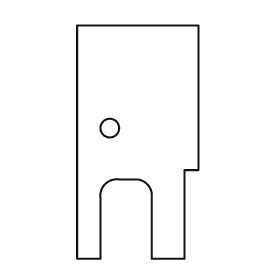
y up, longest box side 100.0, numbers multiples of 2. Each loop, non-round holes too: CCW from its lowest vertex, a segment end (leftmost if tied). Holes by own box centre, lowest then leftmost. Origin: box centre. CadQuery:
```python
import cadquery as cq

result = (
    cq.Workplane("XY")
    .moveTo(-26.0, -50.0)
    .lineTo(-16.0, -50.0)
    .lineTo(-16.0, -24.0)
    .threePointArc((-14.0, -18.0), (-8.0, -16.0))
    .lineTo(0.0, -16.0)
    .threePointArc((4.0, -18.0), (6.0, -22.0))
    .lineTo(6.0, -50.0)
    .lineTo(20.0, -50.0)
    .lineTo(20.0, -12.0)
    .lineTo(26.0, -12.0)
    .lineTo(26.0, 50.0)
    .lineTo(-26.0, 50.0)
    .close()
    .moveTo(-12.0, 6.0)
    .circle(4.0)
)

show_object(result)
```